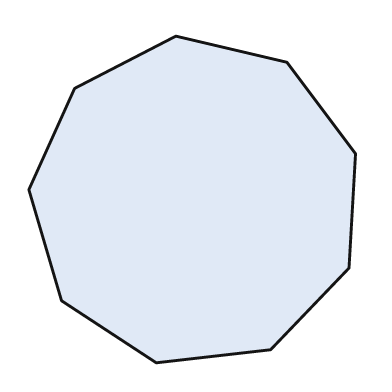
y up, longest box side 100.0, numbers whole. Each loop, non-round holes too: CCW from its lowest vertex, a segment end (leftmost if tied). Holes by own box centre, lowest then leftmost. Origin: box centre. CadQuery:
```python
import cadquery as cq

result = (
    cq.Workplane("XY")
    .moveTo(-11.0, -50.0)
    .lineTo(24.0, -46.0)
    .lineTo(48.0, -21.0)
    .lineTo(50.0, 14.0)
    .lineTo(29.0, 42.0)
    .lineTo(-5.0, 50.0)
    .lineTo(-36.0, 34.0)
    .lineTo(-50.0, 3.0)
    .lineTo(-40.0, -31.0)
    .close()
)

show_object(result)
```